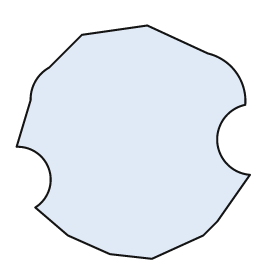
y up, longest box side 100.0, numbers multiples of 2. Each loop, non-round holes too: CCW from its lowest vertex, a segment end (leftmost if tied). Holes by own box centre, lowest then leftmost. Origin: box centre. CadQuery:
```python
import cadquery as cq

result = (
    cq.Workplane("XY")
    .moveTo(8.0, -50.0)
    .lineTo(30.0, -40.0)
    .lineTo(36.0, -34.0)
    .lineTo(50.0, -14.0)
    .threePointArc((36.0, 0.0), (48.0, 16.0))
    .threePointArc((44.0, 30.0), (32.0, 38.0))
    .lineTo(6.0, 50.0)
    .lineTo(-22.0, 46.0)
    .lineTo(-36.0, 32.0)
    .threePointArc((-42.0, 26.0), (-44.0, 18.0))
    .lineTo(-50.0, -2.0)
    .threePointArc((-36.0, -12.0), (-42.0, -28.0))
    .lineTo(-28.0, -40.0)
    .lineTo(-10.0, -48.0)
    .close()
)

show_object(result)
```